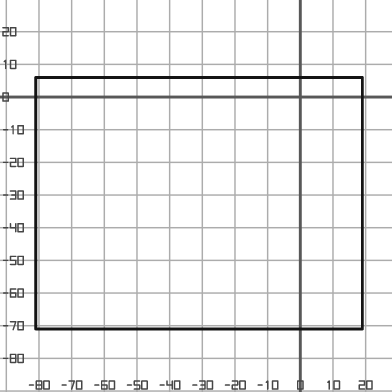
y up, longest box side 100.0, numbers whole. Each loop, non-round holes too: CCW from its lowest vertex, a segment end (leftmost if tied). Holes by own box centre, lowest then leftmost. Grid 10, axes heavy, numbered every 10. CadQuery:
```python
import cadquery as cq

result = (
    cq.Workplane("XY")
    .moveTo(-81.0, -71.0)
    .lineTo(19.0, -71.0)
    .lineTo(19.0, 6.0)
    .lineTo(-81.0, 6.0)
    .close()
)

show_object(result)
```